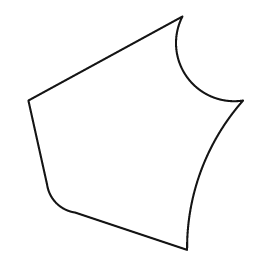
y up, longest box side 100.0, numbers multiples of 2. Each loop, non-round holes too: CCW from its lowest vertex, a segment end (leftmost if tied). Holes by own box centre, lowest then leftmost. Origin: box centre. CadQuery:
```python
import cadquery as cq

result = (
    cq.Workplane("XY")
    .moveTo(22.0, -50.0)
    .threePointArc((28.0, -16.0), (46.0, 14.0))
    .threePointArc((22.0, 24.0), (20.0, 50.0))
    .lineTo(-46.0, 14.0)
    .lineTo(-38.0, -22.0)
    .threePointArc((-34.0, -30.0), (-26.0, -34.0))
    .close()
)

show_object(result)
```